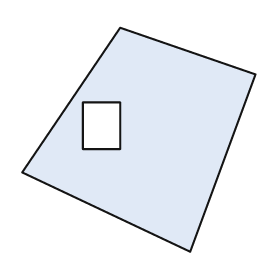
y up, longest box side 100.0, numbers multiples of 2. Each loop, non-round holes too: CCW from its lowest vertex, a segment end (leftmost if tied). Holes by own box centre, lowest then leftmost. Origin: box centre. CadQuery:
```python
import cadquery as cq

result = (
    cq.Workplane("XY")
    .moveTo(22.0, -48.0)
    .lineTo(50.0, 28.0)
    .lineTo(-8.0, 48.0)
    .lineTo(-50.0, -14.0)
    .close()
    .moveTo(-24.0, -4.0)
    .lineTo(-8.0, -4.0)
    .lineTo(-8.0, 16.0)
    .lineTo(-24.0, 16.0)
    .close()
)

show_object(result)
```